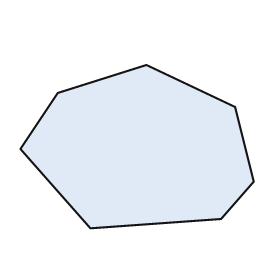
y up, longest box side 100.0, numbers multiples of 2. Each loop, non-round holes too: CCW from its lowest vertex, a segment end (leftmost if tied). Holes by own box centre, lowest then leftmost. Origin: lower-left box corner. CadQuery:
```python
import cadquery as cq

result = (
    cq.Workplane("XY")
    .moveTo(30.0, 0.0)
    .lineTo(86.0, 4.0)
    .lineTo(100.0, 20.0)
    .lineTo(92.0, 52.0)
    .lineTo(54.0, 70.0)
    .lineTo(16.0, 58.0)
    .lineTo(0.0, 34.0)
    .close()
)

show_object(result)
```